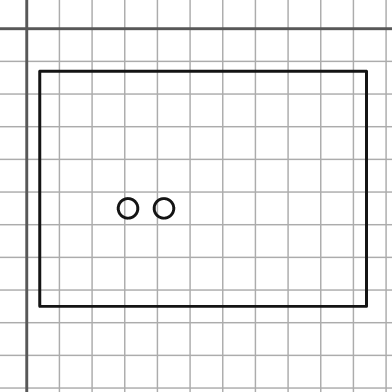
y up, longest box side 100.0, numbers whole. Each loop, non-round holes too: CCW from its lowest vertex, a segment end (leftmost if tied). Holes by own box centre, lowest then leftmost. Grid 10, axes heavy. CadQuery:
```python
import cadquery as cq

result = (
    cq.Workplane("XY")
    .moveTo(4.0, -85.0)
    .lineTo(104.0, -85.0)
    .lineTo(104.0, -13.0)
    .lineTo(4.0, -13.0)
    .close()
    .moveTo(31.0, -55.0)
    .circle(3.0)
    .moveTo(42.0, -55.0)
    .circle(3.0)
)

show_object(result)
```